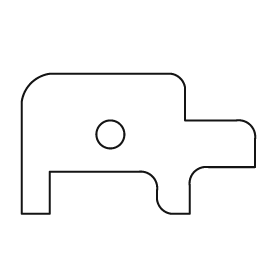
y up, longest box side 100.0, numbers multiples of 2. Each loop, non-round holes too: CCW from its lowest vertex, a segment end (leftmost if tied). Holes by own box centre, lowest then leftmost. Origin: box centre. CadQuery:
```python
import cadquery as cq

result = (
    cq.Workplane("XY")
    .moveTo(-50.0, -30.0)
    .lineTo(-38.0, -30.0)
    .lineTo(-38.0, -12.0)
    .lineTo(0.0, -12.0)
    .threePointArc((6.0, -14.0), (8.0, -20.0))
    .lineTo(8.0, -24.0)
    .threePointArc((10.0, -28.0), (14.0, -30.0))
    .lineTo(22.0, -30.0)
    .lineTo(22.0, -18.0)
    .threePointArc((24.0, -12.0), (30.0, -10.0))
    .lineTo(50.0, -10.0)
    .lineTo(50.0, 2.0)
    .threePointArc((48.0, 8.0), (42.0, 10.0))
    .lineTo(20.0, 10.0)
    .lineTo(20.0, 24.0)
    .threePointArc((18.0, 28.0), (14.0, 30.0))
    .lineTo(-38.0, 30.0)
    .threePointArc((-46.0, 26.0), (-50.0, 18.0))
    .close()
    .moveTo(-12.0, 4.0)
    .circle(6.0)
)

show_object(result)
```